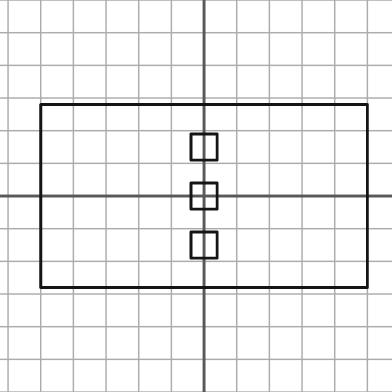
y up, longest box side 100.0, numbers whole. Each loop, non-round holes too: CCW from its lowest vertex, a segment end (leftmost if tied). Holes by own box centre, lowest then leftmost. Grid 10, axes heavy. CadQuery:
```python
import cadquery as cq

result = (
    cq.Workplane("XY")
    .moveTo(-50.0, -28.0)
    .lineTo(50.0, -28.0)
    .lineTo(50.0, 28.0)
    .lineTo(-50.0, 28.0)
    .close()
    .moveTo(-4.0, -19.0)
    .lineTo(4.0, -19.0)
    .lineTo(4.0, -11.0)
    .lineTo(-4.0, -11.0)
    .close()
    .moveTo(-4.0, -4.0)
    .lineTo(4.0, -4.0)
    .lineTo(4.0, 4.0)
    .lineTo(-4.0, 4.0)
    .close()
    .moveTo(-4.0, 11.0)
    .lineTo(4.0, 11.0)
    .lineTo(4.0, 19.0)
    .lineTo(-4.0, 19.0)
    .close()
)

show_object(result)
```